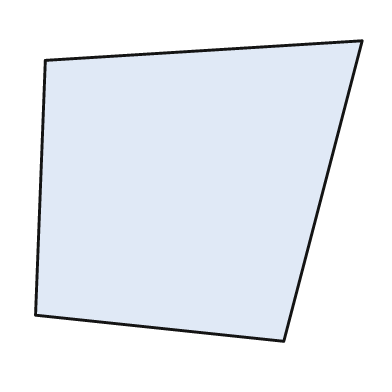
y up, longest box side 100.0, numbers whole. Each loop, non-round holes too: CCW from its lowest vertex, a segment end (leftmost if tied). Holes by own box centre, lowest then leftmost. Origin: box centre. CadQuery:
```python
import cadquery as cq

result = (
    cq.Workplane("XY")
    .moveTo(26.0, -46.0)
    .lineTo(50.0, 46.0)
    .lineTo(-47.0, 40.0)
    .lineTo(-50.0, -38.0)
    .close()
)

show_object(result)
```